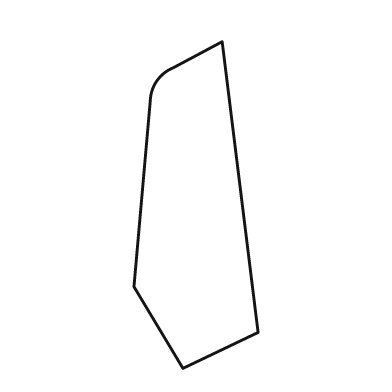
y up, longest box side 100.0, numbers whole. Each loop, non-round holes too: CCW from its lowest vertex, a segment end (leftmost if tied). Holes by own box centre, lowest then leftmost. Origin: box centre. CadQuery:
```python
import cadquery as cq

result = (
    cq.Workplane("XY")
    .moveTo(-4.0, -50.0)
    .lineTo(19.0, -39.0)
    .lineTo(8.0, 50.0)
    .lineTo(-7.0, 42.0)
    .threePointArc((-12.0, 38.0), (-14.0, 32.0))
    .lineTo(-19.0, -25.0)
    .close()
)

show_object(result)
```